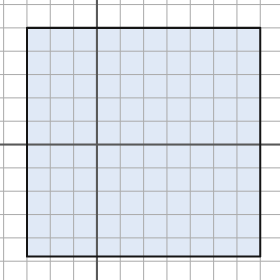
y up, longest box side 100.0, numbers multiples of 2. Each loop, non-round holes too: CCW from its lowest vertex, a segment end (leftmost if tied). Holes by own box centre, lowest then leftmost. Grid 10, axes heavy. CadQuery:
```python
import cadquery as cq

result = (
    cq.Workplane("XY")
    .moveTo(-30.0, -48.0)
    .lineTo(70.0, -48.0)
    .lineTo(70.0, 50.0)
    .lineTo(-30.0, 50.0)
    .close()
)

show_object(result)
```